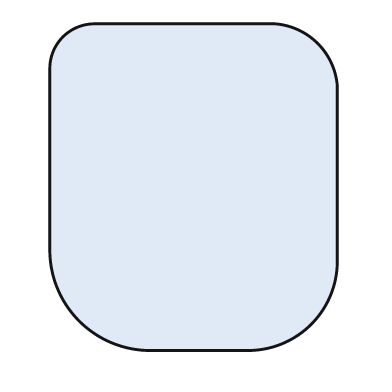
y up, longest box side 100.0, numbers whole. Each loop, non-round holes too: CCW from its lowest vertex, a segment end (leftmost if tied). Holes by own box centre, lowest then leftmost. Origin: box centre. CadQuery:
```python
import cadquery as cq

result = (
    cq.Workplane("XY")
    .moveTo(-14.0, -50.0)
    .lineTo(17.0, -50.0)
    .threePointArc((36.0, -42.0), (44.0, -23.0))
    .lineTo(44.0, 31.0)
    .threePointArc((38.0, 44.0), (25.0, 50.0))
    .lineTo(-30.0, 50.0)
    .threePointArc((-40.0, 46.0), (-44.0, 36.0))
    .lineTo(-44.0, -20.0)
    .threePointArc((-35.0, -41.0), (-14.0, -50.0))
    .close()
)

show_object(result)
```